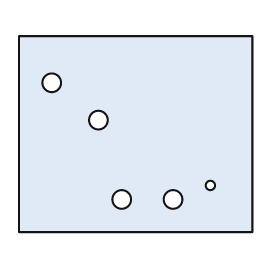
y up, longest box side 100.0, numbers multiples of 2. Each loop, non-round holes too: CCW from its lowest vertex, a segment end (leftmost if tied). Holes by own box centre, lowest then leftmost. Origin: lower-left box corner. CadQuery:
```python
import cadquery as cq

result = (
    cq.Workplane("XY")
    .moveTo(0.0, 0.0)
    .lineTo(100.0, 0.0)
    .lineTo(100.0, 84.0)
    .lineTo(0.0, 84.0)
    .close()
    .moveTo(44.0, 14.0)
    .circle(4.0)
    .moveTo(66.0, 14.0)
    .circle(4.0)
    .moveTo(82.0, 20.0)
    .circle(2.0)
    .moveTo(34.0, 48.0)
    .circle(4.0)
    .moveTo(14.0, 64.0)
    .circle(4.0)
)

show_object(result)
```